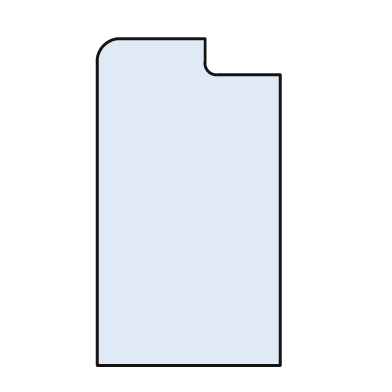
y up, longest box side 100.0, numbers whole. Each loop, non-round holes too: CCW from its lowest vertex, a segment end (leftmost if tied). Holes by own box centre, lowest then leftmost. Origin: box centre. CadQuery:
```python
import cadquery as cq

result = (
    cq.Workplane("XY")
    .moveTo(-28.0, -50.0)
    .lineTo(28.0, -50.0)
    .lineTo(28.0, 39.0)
    .lineTo(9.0, 39.0)
    .threePointArc((6.0, 40.0), (5.0, 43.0))
    .lineTo(5.0, 50.0)
    .lineTo(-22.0, 50.0)
    .threePointArc((-26.0, 48.0), (-28.0, 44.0))
    .close()
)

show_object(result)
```